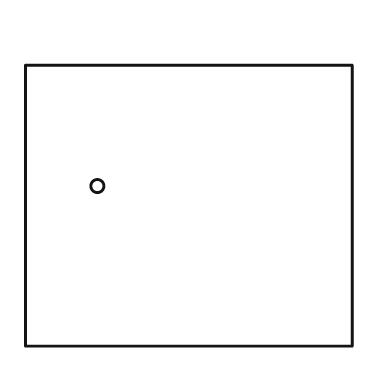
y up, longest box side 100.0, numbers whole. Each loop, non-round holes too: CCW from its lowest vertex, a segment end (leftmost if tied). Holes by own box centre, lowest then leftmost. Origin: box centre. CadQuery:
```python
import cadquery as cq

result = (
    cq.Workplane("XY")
    .moveTo(-50.0, -43.0)
    .lineTo(50.0, -43.0)
    .lineTo(50.0, 43.0)
    .lineTo(-50.0, 43.0)
    .close()
    .moveTo(-28.0, 6.0)
    .circle(2.0)
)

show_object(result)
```